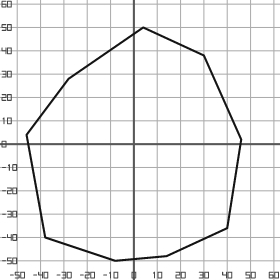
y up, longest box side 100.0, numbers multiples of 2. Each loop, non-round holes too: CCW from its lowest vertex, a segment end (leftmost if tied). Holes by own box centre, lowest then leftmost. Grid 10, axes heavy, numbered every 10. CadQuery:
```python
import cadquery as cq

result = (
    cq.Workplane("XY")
    .moveTo(-8.0, -50.0)
    .lineTo(14.0, -48.0)
    .lineTo(40.0, -36.0)
    .lineTo(46.0, 2.0)
    .lineTo(30.0, 38.0)
    .lineTo(4.0, 50.0)
    .lineTo(-28.0, 28.0)
    .lineTo(-46.0, 4.0)
    .lineTo(-38.0, -40.0)
    .close()
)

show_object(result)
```